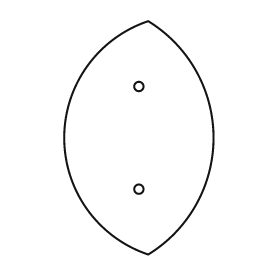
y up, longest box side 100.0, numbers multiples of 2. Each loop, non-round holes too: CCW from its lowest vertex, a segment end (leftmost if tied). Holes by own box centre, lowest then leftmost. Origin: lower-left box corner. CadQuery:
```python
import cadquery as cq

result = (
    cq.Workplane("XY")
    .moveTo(36.0, 0.0)
    .threePointArc((64.0, 50.0), (36.0, 100.0))
    .threePointArc((0.0, 50.0), (36.0, 0.0))
    .close()
    .moveTo(32.0, 28.0)
    .circle(2.0)
    .moveTo(32.0, 72.0)
    .circle(2.0)
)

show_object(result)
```